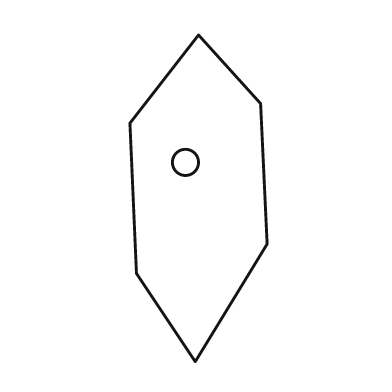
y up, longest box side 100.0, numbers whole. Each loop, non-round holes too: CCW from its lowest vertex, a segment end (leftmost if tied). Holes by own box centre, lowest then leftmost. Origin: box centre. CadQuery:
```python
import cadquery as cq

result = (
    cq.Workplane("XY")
    .moveTo(-1.0, -50.0)
    .lineTo(21.0, -14.0)
    .lineTo(19.0, 29.0)
    .lineTo(0.0, 50.0)
    .lineTo(-21.0, 23.0)
    .lineTo(-19.0, -23.0)
    .close()
    .moveTo(-4.0, 11.0)
    .circle(4.0)
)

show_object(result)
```